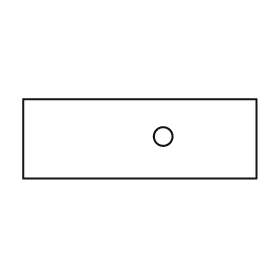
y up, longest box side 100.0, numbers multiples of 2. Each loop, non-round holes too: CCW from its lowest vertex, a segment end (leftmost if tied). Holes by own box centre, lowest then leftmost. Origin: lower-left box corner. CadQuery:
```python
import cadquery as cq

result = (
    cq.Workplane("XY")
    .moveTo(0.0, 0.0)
    .lineTo(100.0, 0.0)
    .lineTo(100.0, 34.0)
    .lineTo(0.0, 34.0)
    .close()
    .moveTo(60.0, 18.0)
    .circle(4.0)
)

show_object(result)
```